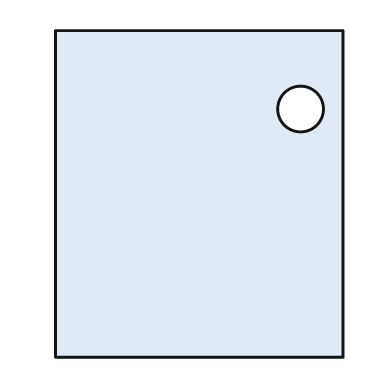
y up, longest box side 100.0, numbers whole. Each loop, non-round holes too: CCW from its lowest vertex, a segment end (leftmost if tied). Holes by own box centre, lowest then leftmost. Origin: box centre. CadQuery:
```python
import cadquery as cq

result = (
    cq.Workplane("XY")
    .moveTo(-44.0, -50.0)
    .lineTo(44.0, -50.0)
    .lineTo(44.0, 50.0)
    .lineTo(-44.0, 50.0)
    .close()
    .moveTo(31.0, 26.0)
    .circle(7.0)
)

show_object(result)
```